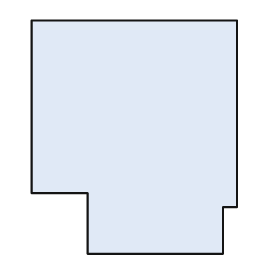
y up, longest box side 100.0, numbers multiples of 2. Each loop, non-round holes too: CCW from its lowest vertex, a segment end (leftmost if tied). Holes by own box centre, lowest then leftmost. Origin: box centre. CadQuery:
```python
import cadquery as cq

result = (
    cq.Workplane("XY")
    .moveTo(-20.0, -50.0)
    .lineTo(38.0, -50.0)
    .lineTo(38.0, -30.0)
    .lineTo(44.0, -30.0)
    .lineTo(44.0, 50.0)
    .lineTo(-44.0, 50.0)
    .lineTo(-44.0, -24.0)
    .lineTo(-20.0, -24.0)
    .close()
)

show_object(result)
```